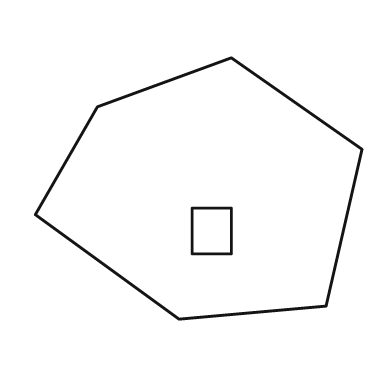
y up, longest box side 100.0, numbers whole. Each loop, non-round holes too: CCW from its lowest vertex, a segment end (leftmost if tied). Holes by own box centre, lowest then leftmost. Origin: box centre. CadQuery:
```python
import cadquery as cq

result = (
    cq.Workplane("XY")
    .moveTo(-6.0, -40.0)
    .lineTo(39.0, -36.0)
    .lineTo(50.0, 12.0)
    .lineTo(10.0, 40.0)
    .lineTo(-31.0, 25.0)
    .lineTo(-50.0, -8.0)
    .close()
    .moveTo(-2.0, -20.0)
    .lineTo(10.0, -20.0)
    .lineTo(10.0, -6.0)
    .lineTo(-2.0, -6.0)
    .close()
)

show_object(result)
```